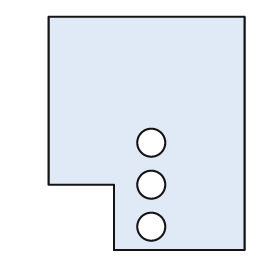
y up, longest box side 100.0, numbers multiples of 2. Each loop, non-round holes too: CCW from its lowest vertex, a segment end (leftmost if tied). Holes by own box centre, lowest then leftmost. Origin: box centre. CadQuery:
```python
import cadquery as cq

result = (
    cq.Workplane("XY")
    .moveTo(-14.0, -50.0)
    .lineTo(42.0, -50.0)
    .lineTo(42.0, 50.0)
    .lineTo(-42.0, 50.0)
    .lineTo(-42.0, -22.0)
    .lineTo(-14.0, -22.0)
    .close()
    .moveTo(2.0, -40.0)
    .circle(6.0)
    .moveTo(2.0, -22.0)
    .circle(6.0)
    .moveTo(2.0, -4.0)
    .circle(6.0)
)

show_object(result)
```